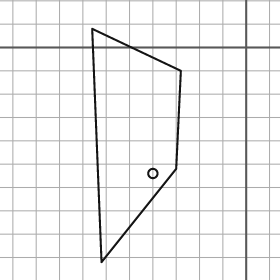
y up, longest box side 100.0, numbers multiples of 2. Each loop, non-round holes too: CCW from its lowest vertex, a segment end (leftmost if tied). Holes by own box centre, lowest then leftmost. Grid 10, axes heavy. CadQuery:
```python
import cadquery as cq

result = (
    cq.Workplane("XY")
    .moveTo(-62.0, -92.0)
    .lineTo(-30.0, -52.0)
    .lineTo(-28.0, -10.0)
    .lineTo(-66.0, 8.0)
    .close()
    .moveTo(-40.0, -54.0)
    .circle(2.0)
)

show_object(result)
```